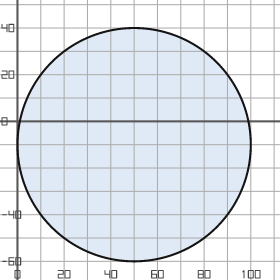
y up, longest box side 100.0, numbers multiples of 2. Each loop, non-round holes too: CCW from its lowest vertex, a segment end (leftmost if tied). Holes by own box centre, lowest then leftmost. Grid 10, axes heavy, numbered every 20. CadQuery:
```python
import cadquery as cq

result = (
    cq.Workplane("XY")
    .moveTo(50.0, -10.0)
    .circle(50.0)
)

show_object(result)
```